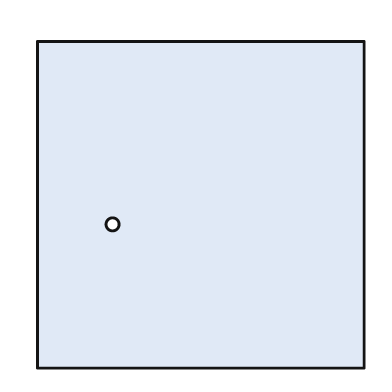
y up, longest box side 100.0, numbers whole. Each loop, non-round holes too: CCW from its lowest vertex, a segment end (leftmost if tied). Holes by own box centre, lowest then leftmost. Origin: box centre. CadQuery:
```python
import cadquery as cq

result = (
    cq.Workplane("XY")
    .moveTo(-50.0, -50.0)
    .lineTo(50.0, -50.0)
    .lineTo(50.0, 50.0)
    .lineTo(-50.0, 50.0)
    .close()
    .moveTo(-27.0, -6.0)
    .circle(2.0)
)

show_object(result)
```